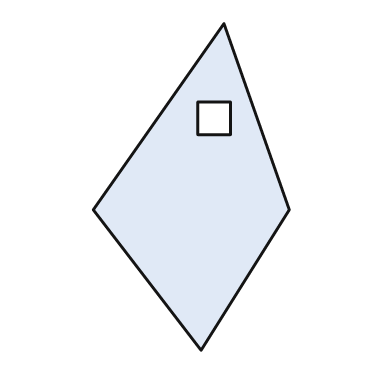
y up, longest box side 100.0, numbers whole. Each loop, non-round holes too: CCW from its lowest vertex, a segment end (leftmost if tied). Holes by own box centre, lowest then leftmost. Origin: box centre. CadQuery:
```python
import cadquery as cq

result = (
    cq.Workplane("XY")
    .moveTo(3.0, -50.0)
    .lineTo(30.0, -7.0)
    .lineTo(10.0, 50.0)
    .lineTo(-30.0, -7.0)
    .close()
    .moveTo(2.0, 16.0)
    .lineTo(12.0, 16.0)
    .lineTo(12.0, 26.0)
    .lineTo(2.0, 26.0)
    .close()
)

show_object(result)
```